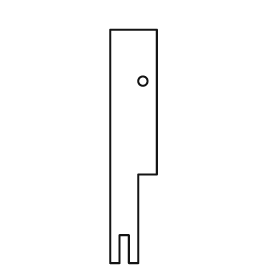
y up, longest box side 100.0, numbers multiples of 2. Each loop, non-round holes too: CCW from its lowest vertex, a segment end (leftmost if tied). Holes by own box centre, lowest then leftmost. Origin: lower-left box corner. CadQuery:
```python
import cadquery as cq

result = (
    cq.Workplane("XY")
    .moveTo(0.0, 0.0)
    .lineTo(4.0, 0.0)
    .lineTo(4.0, 12.0)
    .lineTo(8.0, 12.0)
    .lineTo(8.0, 0.0)
    .lineTo(12.0, 0.0)
    .lineTo(12.0, 38.0)
    .lineTo(20.0, 38.0)
    .lineTo(20.0, 100.0)
    .lineTo(0.0, 100.0)
    .close()
    .moveTo(14.0, 78.0)
    .circle(2.0)
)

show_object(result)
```